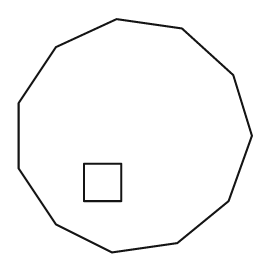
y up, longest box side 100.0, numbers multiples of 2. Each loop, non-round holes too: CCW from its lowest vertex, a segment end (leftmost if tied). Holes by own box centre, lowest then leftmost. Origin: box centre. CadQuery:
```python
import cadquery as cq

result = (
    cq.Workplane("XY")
    .moveTo(-10.0, -50.0)
    .lineTo(18.0, -46.0)
    .lineTo(40.0, -28.0)
    .lineTo(50.0, 0.0)
    .lineTo(42.0, 26.0)
    .lineTo(20.0, 46.0)
    .lineTo(-8.0, 50.0)
    .lineTo(-34.0, 38.0)
    .lineTo(-50.0, 14.0)
    .lineTo(-50.0, -14.0)
    .lineTo(-34.0, -38.0)
    .close()
    .moveTo(-22.0, -28.0)
    .lineTo(-6.0, -28.0)
    .lineTo(-6.0, -12.0)
    .lineTo(-22.0, -12.0)
    .close()
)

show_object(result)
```